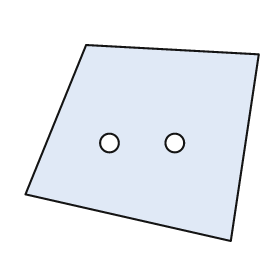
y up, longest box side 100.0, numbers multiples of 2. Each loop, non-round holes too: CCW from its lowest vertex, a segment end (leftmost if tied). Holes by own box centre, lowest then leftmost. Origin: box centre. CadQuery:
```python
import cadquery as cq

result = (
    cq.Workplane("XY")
    .moveTo(38.0, -42.0)
    .lineTo(50.0, 38.0)
    .lineTo(-24.0, 42.0)
    .lineTo(-50.0, -22.0)
    .close()
    .moveTo(-14.0, 0.0)
    .circle(4.0)
    .moveTo(14.0, 0.0)
    .circle(4.0)
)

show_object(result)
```